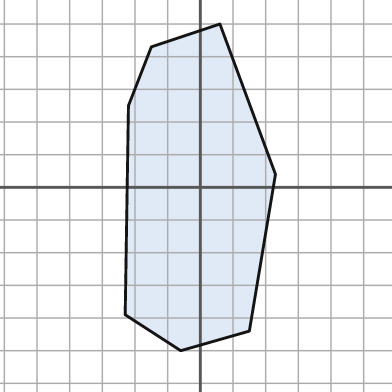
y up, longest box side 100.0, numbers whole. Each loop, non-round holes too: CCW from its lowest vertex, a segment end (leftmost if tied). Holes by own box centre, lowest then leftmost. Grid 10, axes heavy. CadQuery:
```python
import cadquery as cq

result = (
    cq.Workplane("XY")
    .moveTo(-6.0, -50.0)
    .lineTo(15.0, -44.0)
    .lineTo(23.0, 4.0)
    .lineTo(6.0, 50.0)
    .lineTo(-15.0, 43.0)
    .lineTo(-22.0, 25.0)
    .lineTo(-23.0, -39.0)
    .close()
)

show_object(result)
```